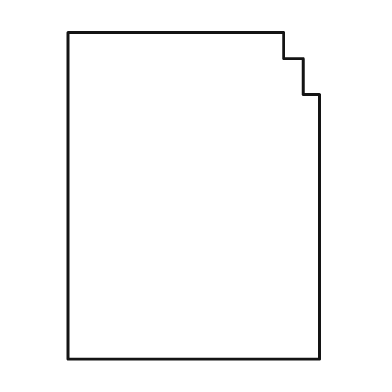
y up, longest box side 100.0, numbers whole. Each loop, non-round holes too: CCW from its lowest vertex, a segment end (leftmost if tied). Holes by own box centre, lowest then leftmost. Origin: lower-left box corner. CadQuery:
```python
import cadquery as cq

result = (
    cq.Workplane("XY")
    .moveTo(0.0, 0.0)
    .lineTo(77.0, 0.0)
    .lineTo(77.0, 81.0)
    .lineTo(72.0, 81.0)
    .lineTo(72.0, 92.0)
    .lineTo(66.0, 92.0)
    .lineTo(66.0, 100.0)
    .lineTo(0.0, 100.0)
    .close()
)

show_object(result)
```